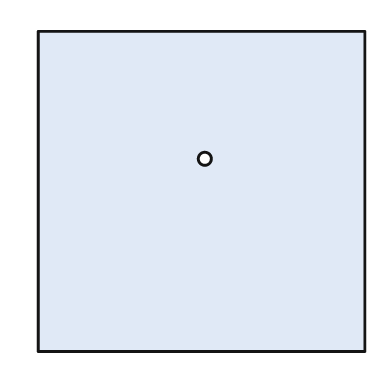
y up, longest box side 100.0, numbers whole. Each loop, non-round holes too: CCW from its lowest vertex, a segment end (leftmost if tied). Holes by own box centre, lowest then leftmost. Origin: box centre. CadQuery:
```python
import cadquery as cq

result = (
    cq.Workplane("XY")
    .moveTo(-50.0, -49.0)
    .lineTo(50.0, -49.0)
    .lineTo(50.0, 49.0)
    .lineTo(-50.0, 49.0)
    .close()
    .moveTo(1.0, 10.0)
    .circle(2.0)
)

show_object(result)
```